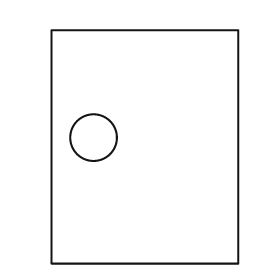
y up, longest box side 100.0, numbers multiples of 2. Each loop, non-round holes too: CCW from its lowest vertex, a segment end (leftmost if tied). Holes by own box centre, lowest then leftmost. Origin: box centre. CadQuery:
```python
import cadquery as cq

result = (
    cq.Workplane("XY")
    .moveTo(-40.0, -50.0)
    .lineTo(40.0, -50.0)
    .lineTo(40.0, 50.0)
    .lineTo(-40.0, 50.0)
    .close()
    .moveTo(-22.0, 4.0)
    .circle(10.0)
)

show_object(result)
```